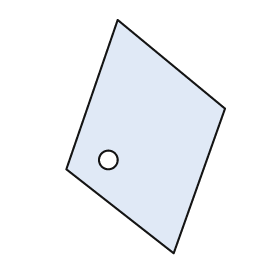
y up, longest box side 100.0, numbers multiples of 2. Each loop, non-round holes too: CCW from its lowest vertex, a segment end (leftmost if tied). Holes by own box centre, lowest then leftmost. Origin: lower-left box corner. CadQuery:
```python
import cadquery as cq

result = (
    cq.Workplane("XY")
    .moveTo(46.0, 0.0)
    .lineTo(68.0, 62.0)
    .lineTo(22.0, 100.0)
    .lineTo(0.0, 36.0)
    .close()
    .moveTo(18.0, 40.0)
    .circle(4.0)
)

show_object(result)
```